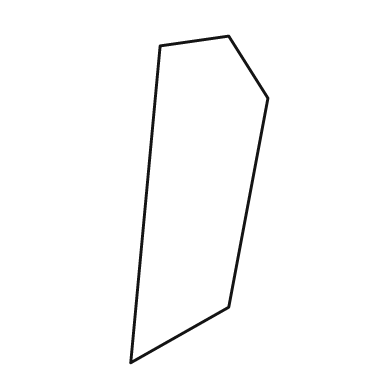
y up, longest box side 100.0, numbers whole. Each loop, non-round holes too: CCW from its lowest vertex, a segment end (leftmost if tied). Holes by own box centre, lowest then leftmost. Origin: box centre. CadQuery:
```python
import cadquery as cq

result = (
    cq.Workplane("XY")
    .moveTo(-21.0, -50.0)
    .lineTo(9.0, -33.0)
    .lineTo(21.0, 31.0)
    .lineTo(9.0, 50.0)
    .lineTo(-12.0, 47.0)
    .close()
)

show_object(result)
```